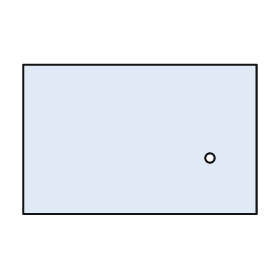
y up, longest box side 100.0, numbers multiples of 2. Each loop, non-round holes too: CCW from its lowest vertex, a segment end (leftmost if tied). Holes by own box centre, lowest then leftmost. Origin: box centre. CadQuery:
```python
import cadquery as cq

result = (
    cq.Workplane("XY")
    .moveTo(-50.0, -32.0)
    .lineTo(50.0, -32.0)
    .lineTo(50.0, 32.0)
    .lineTo(-50.0, 32.0)
    .close()
    .moveTo(30.0, -8.0)
    .circle(2.0)
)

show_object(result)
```